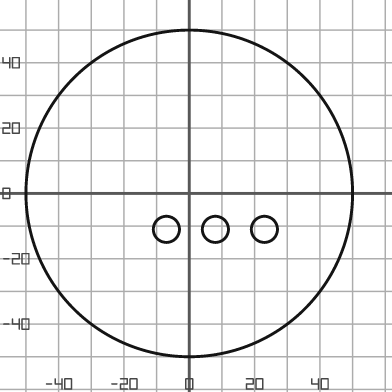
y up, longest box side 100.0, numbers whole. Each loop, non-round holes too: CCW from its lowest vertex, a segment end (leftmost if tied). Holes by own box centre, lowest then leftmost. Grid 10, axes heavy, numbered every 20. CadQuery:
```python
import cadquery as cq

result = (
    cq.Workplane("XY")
    .moveTo(0.0, 0.0)
    .circle(50.0)
    .moveTo(-7.0, -11.0)
    .circle(4.0)
    .moveTo(8.0, -11.0)
    .circle(4.0)
    .moveTo(23.0, -11.0)
    .circle(4.0)
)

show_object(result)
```